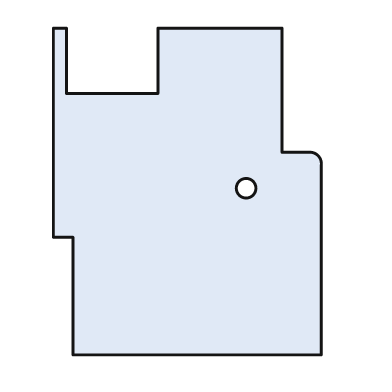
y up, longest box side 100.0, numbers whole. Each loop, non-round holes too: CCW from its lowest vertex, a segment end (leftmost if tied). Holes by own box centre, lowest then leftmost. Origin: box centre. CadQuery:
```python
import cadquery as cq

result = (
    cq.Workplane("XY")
    .moveTo(-35.0, -50.0)
    .lineTo(41.0, -50.0)
    .lineTo(41.0, 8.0)
    .threePointArc((40.0, 11.0), (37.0, 12.0))
    .lineTo(29.0, 12.0)
    .lineTo(29.0, 50.0)
    .lineTo(-9.0, 50.0)
    .lineTo(-9.0, 30.0)
    .lineTo(-37.0, 30.0)
    .lineTo(-37.0, 50.0)
    .lineTo(-41.0, 50.0)
    .lineTo(-41.0, -14.0)
    .lineTo(-35.0, -14.0)
    .close()
    .moveTo(18.0, 1.0)
    .circle(3.0)
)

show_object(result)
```